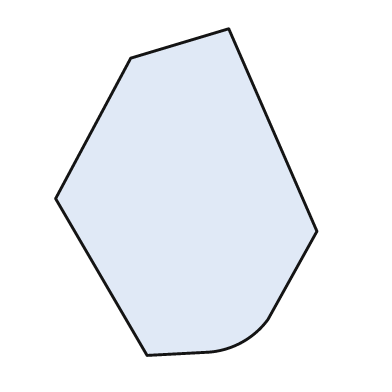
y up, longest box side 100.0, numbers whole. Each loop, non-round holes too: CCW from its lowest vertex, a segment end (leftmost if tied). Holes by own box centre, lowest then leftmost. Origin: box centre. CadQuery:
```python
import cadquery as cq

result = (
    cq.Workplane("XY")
    .moveTo(-12.0, -50.0)
    .lineTo(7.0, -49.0)
    .threePointArc((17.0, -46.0), (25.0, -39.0))
    .lineTo(40.0, -12.0)
    .lineTo(13.0, 50.0)
    .lineTo(-17.0, 41.0)
    .lineTo(-40.0, -2.0)
    .close()
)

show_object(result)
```